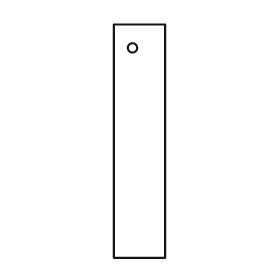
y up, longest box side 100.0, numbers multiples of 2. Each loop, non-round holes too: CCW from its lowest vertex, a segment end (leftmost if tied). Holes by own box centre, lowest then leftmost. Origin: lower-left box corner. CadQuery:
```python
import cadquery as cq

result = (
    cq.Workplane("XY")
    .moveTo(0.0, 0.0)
    .lineTo(22.0, 0.0)
    .lineTo(22.0, 100.0)
    .lineTo(0.0, 100.0)
    .close()
    .moveTo(8.0, 90.0)
    .circle(2.0)
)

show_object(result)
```